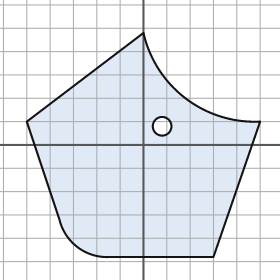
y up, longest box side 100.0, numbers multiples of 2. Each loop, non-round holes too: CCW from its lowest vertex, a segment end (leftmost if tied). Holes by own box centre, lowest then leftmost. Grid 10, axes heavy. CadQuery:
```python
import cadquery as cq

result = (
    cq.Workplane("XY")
    .moveTo(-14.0, -48.0)
    .lineTo(30.0, -48.0)
    .lineTo(50.0, 10.0)
    .threePointArc((18.0, 20.0), (0.0, 48.0))
    .lineTo(-50.0, 10.0)
    .lineTo(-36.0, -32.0)
    .threePointArc((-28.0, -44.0), (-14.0, -48.0))
    .close()
    .moveTo(8.0, 8.0)
    .circle(4.0)
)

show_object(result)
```